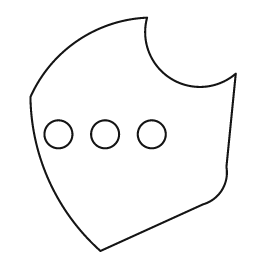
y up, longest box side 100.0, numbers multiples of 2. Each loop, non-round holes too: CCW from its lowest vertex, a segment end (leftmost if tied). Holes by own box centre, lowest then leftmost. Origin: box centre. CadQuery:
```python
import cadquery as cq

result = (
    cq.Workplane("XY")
    .moveTo(-14.0, -50.0)
    .lineTo(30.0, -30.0)
    .threePointArc((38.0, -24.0), (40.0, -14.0))
    .lineTo(44.0, 26.0)
    .threePointArc((16.0, 24.0), (6.0, 50.0))
    .threePointArc((-24.0, 40.0), (-44.0, 16.0))
    .threePointArc((-36.0, -20.0), (-14.0, -50.0))
    .close()
    .moveTo(-32.0, 0.0)
    .circle(6.0)
    .moveTo(-12.0, 0.0)
    .circle(6.0)
    .moveTo(8.0, 0.0)
    .circle(6.0)
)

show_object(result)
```